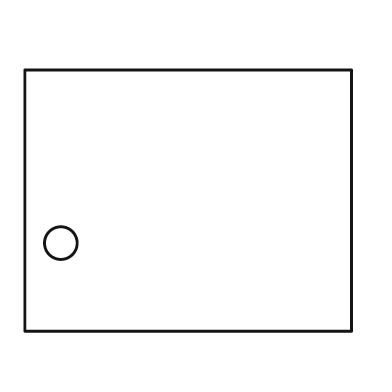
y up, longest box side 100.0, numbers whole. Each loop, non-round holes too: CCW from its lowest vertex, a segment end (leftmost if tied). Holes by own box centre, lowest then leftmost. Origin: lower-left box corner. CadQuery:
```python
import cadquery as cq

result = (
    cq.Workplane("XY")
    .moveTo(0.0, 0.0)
    .lineTo(100.0, 0.0)
    .lineTo(100.0, 80.0)
    .lineTo(0.0, 80.0)
    .close()
    .moveTo(11.0, 27.0)
    .circle(5.0)
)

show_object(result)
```